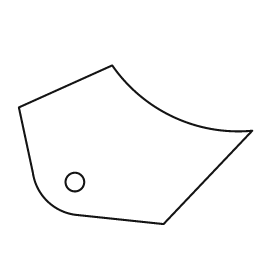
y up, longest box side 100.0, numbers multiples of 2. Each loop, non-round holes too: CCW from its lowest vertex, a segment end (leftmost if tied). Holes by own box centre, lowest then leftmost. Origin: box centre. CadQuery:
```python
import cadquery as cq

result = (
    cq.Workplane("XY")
    .moveTo(12.0, -34.0)
    .lineTo(50.0, 6.0)
    .threePointArc((16.0, 12.0), (-10.0, 34.0))
    .lineTo(-50.0, 16.0)
    .lineTo(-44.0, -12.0)
    .threePointArc((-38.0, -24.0), (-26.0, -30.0))
    .close()
    .moveTo(-26.0, -16.0)
    .circle(4.0)
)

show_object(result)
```